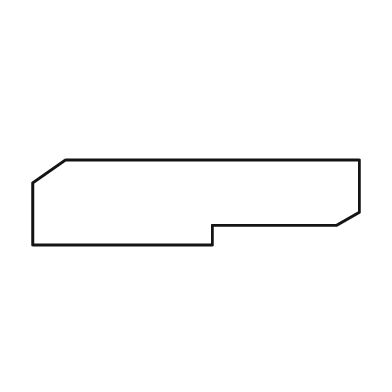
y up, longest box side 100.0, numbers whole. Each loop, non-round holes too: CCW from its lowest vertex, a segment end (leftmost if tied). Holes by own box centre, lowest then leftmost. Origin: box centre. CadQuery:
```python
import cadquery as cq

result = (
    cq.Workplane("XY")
    .moveTo(-50.0, -13.0)
    .lineTo(5.0, -13.0)
    .lineTo(5.0, -7.0)
    .lineTo(43.0, -7.0)
    .lineTo(50.0, -3.0)
    .lineTo(50.0, 13.0)
    .lineTo(-40.0, 13.0)
    .lineTo(-50.0, 6.0)
    .close()
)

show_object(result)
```